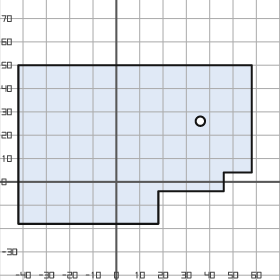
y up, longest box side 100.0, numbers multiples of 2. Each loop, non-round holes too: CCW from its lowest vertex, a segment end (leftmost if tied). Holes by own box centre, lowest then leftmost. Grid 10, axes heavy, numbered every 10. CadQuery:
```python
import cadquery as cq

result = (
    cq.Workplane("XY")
    .moveTo(-42.0, -18.0)
    .lineTo(18.0, -18.0)
    .lineTo(18.0, -4.0)
    .lineTo(46.0, -4.0)
    .lineTo(46.0, 4.0)
    .lineTo(58.0, 4.0)
    .lineTo(58.0, 50.0)
    .lineTo(-42.0, 50.0)
    .close()
    .moveTo(36.0, 26.0)
    .circle(2.0)
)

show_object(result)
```